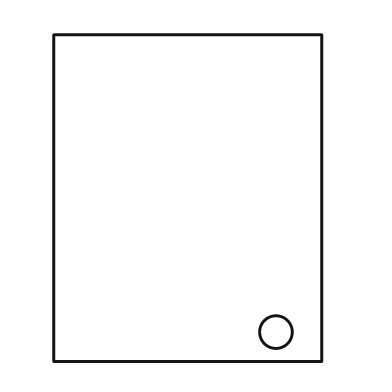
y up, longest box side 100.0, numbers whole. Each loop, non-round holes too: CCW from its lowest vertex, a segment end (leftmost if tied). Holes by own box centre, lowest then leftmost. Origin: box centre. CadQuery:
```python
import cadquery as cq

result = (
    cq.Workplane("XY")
    .moveTo(-41.0, -50.0)
    .lineTo(41.0, -50.0)
    .lineTo(41.0, 50.0)
    .lineTo(-41.0, 50.0)
    .close()
    .moveTo(27.0, -41.0)
    .circle(5.0)
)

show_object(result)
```